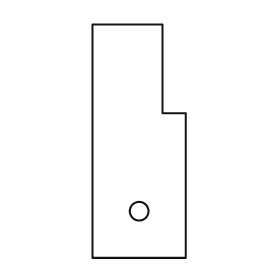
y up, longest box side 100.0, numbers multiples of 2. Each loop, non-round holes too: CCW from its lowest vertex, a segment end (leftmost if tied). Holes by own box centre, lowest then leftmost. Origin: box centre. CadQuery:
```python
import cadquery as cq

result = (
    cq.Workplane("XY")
    .moveTo(-20.0, -50.0)
    .lineTo(20.0, -50.0)
    .lineTo(20.0, 12.0)
    .lineTo(10.0, 12.0)
    .lineTo(10.0, 50.0)
    .lineTo(-20.0, 50.0)
    .close()
    .moveTo(0.0, -30.0)
    .circle(4.0)
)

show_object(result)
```